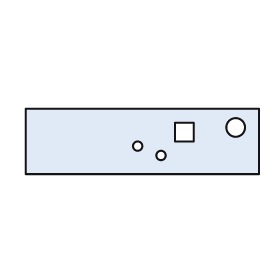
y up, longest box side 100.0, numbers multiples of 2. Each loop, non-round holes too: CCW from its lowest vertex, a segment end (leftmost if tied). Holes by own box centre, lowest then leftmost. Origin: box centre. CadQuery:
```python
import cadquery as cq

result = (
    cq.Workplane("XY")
    .moveTo(-50.0, -14.0)
    .lineTo(50.0, -14.0)
    .lineTo(50.0, 14.0)
    .lineTo(-50.0, 14.0)
    .close()
    .moveTo(8.0, -6.0)
    .circle(2.0)
    .moveTo(-2.0, -2.0)
    .circle(2.0)
    .moveTo(14.0, 0.0)
    .lineTo(22.0, 0.0)
    .lineTo(22.0, 8.0)
    .lineTo(14.0, 8.0)
    .close()
    .moveTo(40.0, 6.0)
    .circle(4.0)
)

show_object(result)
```